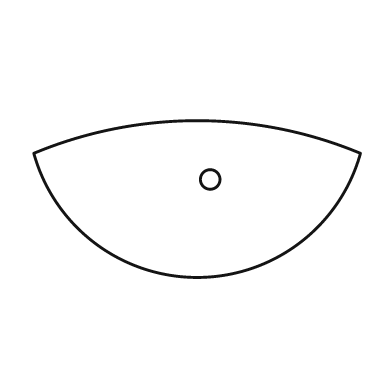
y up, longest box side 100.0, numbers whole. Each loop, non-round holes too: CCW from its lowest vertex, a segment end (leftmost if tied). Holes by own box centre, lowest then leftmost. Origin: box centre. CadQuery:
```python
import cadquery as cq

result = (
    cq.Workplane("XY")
    .moveTo(-50.0, 14.0)
    .threePointArc((0.0, -24.0), (50.0, 14.0))
    .threePointArc((0.0, 24.0), (-50.0, 14.0))
    .close()
    .moveTo(4.0, 6.0)
    .circle(3.0)
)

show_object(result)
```